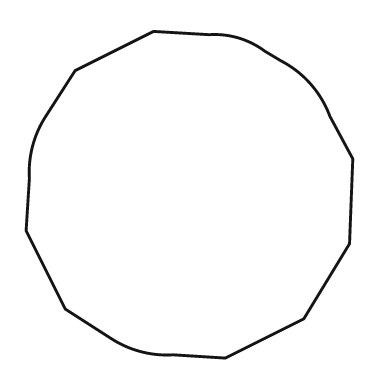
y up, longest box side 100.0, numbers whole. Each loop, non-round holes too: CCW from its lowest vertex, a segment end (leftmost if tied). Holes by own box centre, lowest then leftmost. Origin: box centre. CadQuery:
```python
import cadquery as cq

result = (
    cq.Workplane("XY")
    .moveTo(11.0, -50.0)
    .lineTo(35.0, -38.0)
    .lineTo(49.0, -15.0)
    .lineTo(50.0, 11.0)
    .lineTo(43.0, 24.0)
    .threePointArc((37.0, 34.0), (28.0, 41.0))
    .lineTo(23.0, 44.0)
    .threePointArc((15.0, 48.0), (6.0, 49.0))
    .lineTo(-11.0, 50.0)
    .lineTo(-35.0, 38.0)
    .lineTo(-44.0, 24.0)
    .threePointArc((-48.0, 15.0), (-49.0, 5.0))
    .lineTo(-50.0, -11.0)
    .lineTo(-38.0, -35.0)
    .lineTo(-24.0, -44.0)
    .threePointArc((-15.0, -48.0), (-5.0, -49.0))
    .close()
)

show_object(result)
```